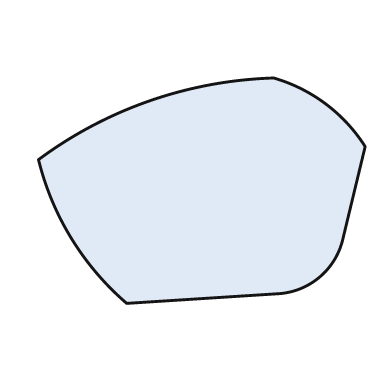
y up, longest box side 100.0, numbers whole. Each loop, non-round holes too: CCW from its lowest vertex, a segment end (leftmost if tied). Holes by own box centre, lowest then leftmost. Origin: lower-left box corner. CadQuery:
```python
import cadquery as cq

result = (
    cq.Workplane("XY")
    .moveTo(27.0, 0.0)
    .lineTo(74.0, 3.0)
    .threePointArc((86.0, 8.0), (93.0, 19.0))
    .lineTo(100.0, 48.0)
    .threePointArc((88.0, 61.0), (72.0, 69.0))
    .threePointArc((34.0, 62.0), (0.0, 44.0))
    .threePointArc((10.0, 20.0), (27.0, 0.0))
    .close()
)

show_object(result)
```